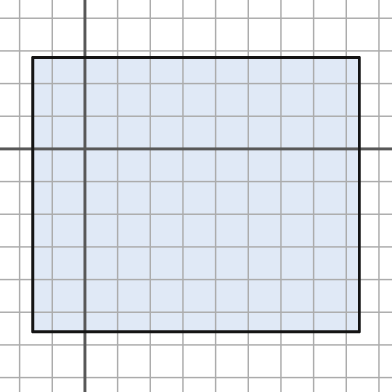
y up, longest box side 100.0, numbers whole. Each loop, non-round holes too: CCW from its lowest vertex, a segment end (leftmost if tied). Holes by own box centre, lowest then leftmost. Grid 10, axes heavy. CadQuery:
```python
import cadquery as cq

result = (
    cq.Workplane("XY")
    .moveTo(-16.0, -56.0)
    .lineTo(84.0, -56.0)
    .lineTo(84.0, 28.0)
    .lineTo(-16.0, 28.0)
    .close()
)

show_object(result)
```